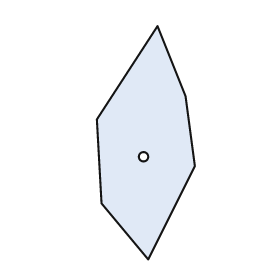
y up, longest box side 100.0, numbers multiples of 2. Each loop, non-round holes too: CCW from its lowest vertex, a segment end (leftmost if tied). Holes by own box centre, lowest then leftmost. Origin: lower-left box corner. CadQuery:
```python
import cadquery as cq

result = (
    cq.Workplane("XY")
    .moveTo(22.0, 0.0)
    .lineTo(42.0, 40.0)
    .lineTo(38.0, 70.0)
    .lineTo(26.0, 100.0)
    .lineTo(0.0, 60.0)
    .lineTo(2.0, 24.0)
    .close()
    .moveTo(20.0, 44.0)
    .circle(2.0)
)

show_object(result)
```